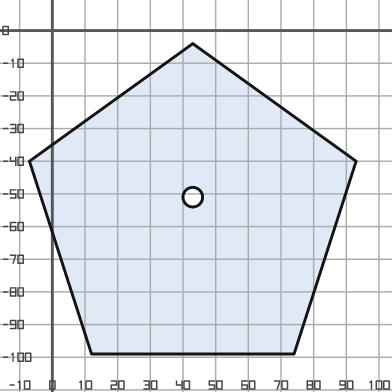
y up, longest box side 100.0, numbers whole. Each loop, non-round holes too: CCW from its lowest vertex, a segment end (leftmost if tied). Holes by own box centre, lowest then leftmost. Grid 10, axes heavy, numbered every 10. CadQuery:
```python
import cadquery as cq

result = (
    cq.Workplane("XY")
    .moveTo(12.0, -99.0)
    .lineTo(74.0, -99.0)
    .lineTo(93.0, -40.0)
    .lineTo(43.0, -4.0)
    .lineTo(-7.0, -40.0)
    .close()
    .moveTo(43.0, -51.0)
    .circle(3.0)
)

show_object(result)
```